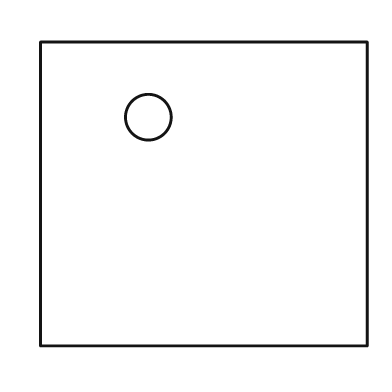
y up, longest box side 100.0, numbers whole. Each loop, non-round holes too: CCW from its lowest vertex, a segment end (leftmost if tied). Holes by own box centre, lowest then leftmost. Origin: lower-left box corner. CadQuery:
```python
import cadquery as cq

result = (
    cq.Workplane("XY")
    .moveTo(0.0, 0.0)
    .lineTo(100.0, 0.0)
    .lineTo(100.0, 93.0)
    .lineTo(0.0, 93.0)
    .close()
    .moveTo(33.0, 70.0)
    .circle(7.0)
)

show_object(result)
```